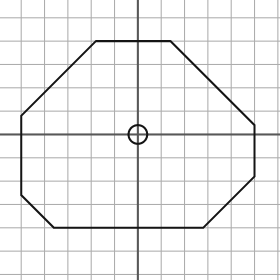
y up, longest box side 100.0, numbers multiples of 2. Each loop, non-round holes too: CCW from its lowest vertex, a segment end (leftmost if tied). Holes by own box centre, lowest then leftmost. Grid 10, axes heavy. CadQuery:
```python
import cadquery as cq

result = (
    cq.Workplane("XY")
    .moveTo(-36.0, -40.0)
    .lineTo(28.0, -40.0)
    .lineTo(50.0, -18.0)
    .lineTo(50.0, 4.0)
    .lineTo(14.0, 40.0)
    .lineTo(-18.0, 40.0)
    .lineTo(-50.0, 8.0)
    .lineTo(-50.0, -26.0)
    .close()
    .moveTo(0.0, 0.0)
    .circle(4.0)
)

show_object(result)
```